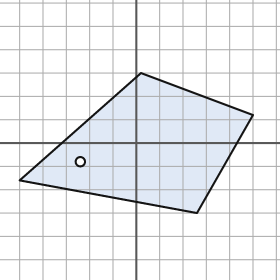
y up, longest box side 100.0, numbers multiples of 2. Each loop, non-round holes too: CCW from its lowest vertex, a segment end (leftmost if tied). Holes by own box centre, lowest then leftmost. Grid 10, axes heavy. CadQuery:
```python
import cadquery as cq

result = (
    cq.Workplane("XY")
    .moveTo(26.0, -30.0)
    .lineTo(50.0, 12.0)
    .lineTo(2.0, 30.0)
    .lineTo(-50.0, -16.0)
    .close()
    .moveTo(-24.0, -8.0)
    .circle(2.0)
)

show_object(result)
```